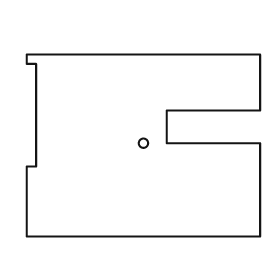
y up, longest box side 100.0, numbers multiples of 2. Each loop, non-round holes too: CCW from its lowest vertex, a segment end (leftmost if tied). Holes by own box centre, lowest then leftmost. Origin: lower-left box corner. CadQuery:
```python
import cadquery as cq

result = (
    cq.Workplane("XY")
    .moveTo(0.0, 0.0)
    .lineTo(100.0, 0.0)
    .lineTo(100.0, 40.0)
    .lineTo(60.0, 40.0)
    .lineTo(60.0, 54.0)
    .lineTo(100.0, 54.0)
    .lineTo(100.0, 78.0)
    .lineTo(0.0, 78.0)
    .lineTo(0.0, 74.0)
    .lineTo(4.0, 74.0)
    .lineTo(4.0, 30.0)
    .lineTo(0.0, 30.0)
    .close()
    .moveTo(50.0, 40.0)
    .circle(2.0)
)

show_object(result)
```